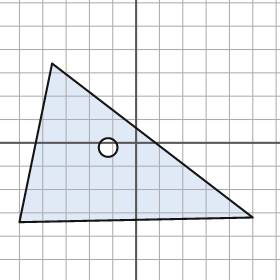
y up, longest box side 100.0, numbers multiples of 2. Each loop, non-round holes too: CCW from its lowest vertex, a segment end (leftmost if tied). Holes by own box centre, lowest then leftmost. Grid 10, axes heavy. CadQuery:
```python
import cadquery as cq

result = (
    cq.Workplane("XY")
    .moveTo(-50.0, -34.0)
    .lineTo(50.0, -32.0)
    .lineTo(-36.0, 34.0)
    .close()
    .moveTo(-12.0, -2.0)
    .circle(4.0)
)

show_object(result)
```